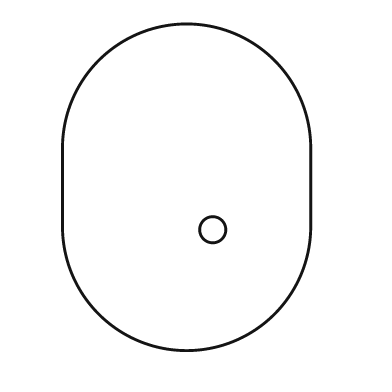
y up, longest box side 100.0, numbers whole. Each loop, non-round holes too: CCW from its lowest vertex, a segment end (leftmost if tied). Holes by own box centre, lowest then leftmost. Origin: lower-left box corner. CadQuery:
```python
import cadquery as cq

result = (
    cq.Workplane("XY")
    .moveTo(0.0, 38.0)
    .threePointArc((38.0, 0.0), (76.0, 38.0))
    .lineTo(76.0, 62.0)
    .threePointArc((38.0, 100.0), (0.0, 62.0))
    .close()
    .moveTo(46.0, 37.0)
    .circle(4.0)
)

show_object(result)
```